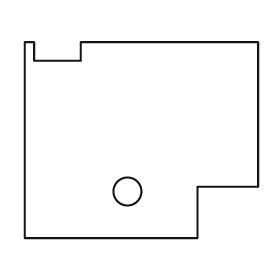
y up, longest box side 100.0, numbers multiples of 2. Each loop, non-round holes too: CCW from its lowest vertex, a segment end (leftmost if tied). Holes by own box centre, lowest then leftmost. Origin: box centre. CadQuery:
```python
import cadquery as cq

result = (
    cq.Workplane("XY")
    .moveTo(-50.0, -42.0)
    .lineTo(24.0, -42.0)
    .lineTo(24.0, -20.0)
    .lineTo(50.0, -20.0)
    .lineTo(50.0, 42.0)
    .lineTo(-26.0, 42.0)
    .lineTo(-26.0, 34.0)
    .lineTo(-46.0, 34.0)
    .lineTo(-46.0, 42.0)
    .lineTo(-50.0, 42.0)
    .close()
    .moveTo(-6.0, -22.0)
    .circle(6.0)
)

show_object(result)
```